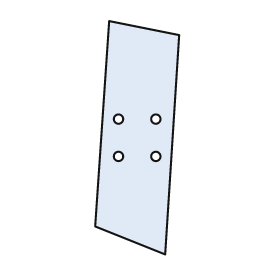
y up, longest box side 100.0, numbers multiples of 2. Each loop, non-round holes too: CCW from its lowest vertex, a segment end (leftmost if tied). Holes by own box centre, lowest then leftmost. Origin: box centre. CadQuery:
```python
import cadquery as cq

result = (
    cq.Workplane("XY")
    .moveTo(12.0, -50.0)
    .lineTo(18.0, 44.0)
    .lineTo(-12.0, 50.0)
    .lineTo(-18.0, -38.0)
    .close()
    .moveTo(-8.0, -8.0)
    .circle(2.0)
    .moveTo(8.0, -8.0)
    .circle(2.0)
    .moveTo(-8.0, 8.0)
    .circle(2.0)
    .moveTo(8.0, 8.0)
    .circle(2.0)
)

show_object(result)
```